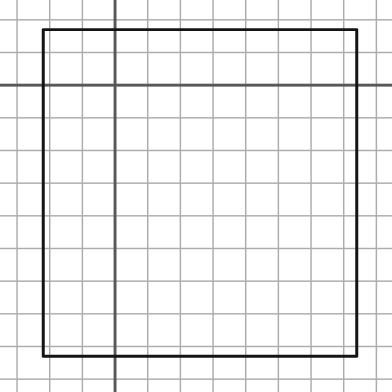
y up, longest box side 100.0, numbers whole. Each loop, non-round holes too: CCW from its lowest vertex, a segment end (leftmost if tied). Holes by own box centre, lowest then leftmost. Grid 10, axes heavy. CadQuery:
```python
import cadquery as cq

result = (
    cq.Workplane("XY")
    .moveTo(-22.0, -83.0)
    .lineTo(74.0, -83.0)
    .lineTo(74.0, 17.0)
    .lineTo(-22.0, 17.0)
    .close()
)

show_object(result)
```